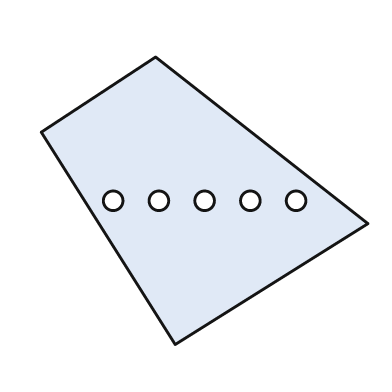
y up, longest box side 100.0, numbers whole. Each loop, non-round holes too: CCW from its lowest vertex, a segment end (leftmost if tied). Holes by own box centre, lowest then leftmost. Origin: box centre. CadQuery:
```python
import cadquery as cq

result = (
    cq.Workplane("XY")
    .moveTo(-9.0, -44.0)
    .lineTo(50.0, -7.0)
    .lineTo(-15.0, 44.0)
    .lineTo(-50.0, 21.0)
    .close()
    .moveTo(-28.0, 0.0)
    .circle(3.0)
    .moveTo(-14.0, 0.0)
    .circle(3.0)
    .moveTo(0.0, 0.0)
    .circle(3.0)
    .moveTo(14.0, 0.0)
    .circle(3.0)
    .moveTo(28.0, 0.0)
    .circle(3.0)
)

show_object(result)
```